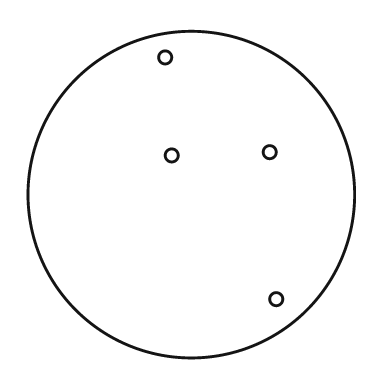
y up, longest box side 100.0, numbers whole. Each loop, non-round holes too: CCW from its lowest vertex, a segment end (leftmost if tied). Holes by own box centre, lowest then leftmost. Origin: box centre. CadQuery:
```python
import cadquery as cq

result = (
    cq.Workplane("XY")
    .moveTo(0.0, 0.0)
    .circle(50.0)
    .moveTo(26.0, -32.0)
    .circle(2.0)
    .moveTo(-6.0, 12.0)
    .circle(2.0)
    .moveTo(24.0, 13.0)
    .circle(2.0)
    .moveTo(-8.0, 42.0)
    .circle(2.0)
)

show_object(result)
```